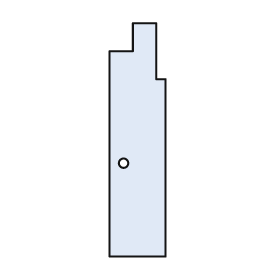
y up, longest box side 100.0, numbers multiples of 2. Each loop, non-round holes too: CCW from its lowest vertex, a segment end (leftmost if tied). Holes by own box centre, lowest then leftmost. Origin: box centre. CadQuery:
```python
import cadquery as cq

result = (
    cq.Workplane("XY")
    .moveTo(-12.0, -50.0)
    .lineTo(12.0, -50.0)
    .lineTo(12.0, 26.0)
    .lineTo(8.0, 26.0)
    .lineTo(8.0, 50.0)
    .lineTo(-2.0, 50.0)
    .lineTo(-2.0, 38.0)
    .lineTo(-12.0, 38.0)
    .close()
    .moveTo(-6.0, -10.0)
    .circle(2.0)
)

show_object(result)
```